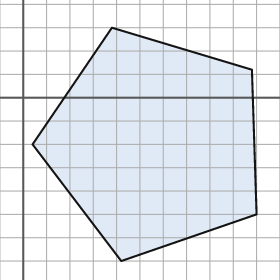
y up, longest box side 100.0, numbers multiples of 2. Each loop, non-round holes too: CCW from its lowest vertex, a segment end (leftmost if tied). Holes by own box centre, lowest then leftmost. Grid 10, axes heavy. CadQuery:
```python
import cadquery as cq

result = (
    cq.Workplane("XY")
    .moveTo(42.0, -70.0)
    .lineTo(100.0, -50.0)
    .lineTo(98.0, 12.0)
    .lineTo(38.0, 30.0)
    .lineTo(4.0, -20.0)
    .close()
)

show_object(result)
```